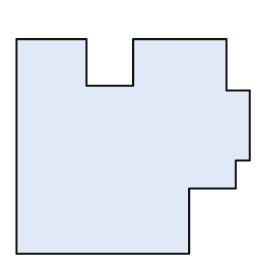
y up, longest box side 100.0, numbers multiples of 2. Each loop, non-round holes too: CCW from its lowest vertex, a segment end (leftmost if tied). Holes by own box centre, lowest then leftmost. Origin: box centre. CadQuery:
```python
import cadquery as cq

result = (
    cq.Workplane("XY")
    .moveTo(-50.0, -46.0)
    .lineTo(24.0, -46.0)
    .lineTo(24.0, -18.0)
    .lineTo(44.0, -18.0)
    .lineTo(44.0, -6.0)
    .lineTo(50.0, -6.0)
    .lineTo(50.0, 24.0)
    .lineTo(40.0, 24.0)
    .lineTo(40.0, 46.0)
    .lineTo(0.0, 46.0)
    .lineTo(0.0, 26.0)
    .lineTo(-20.0, 26.0)
    .lineTo(-20.0, 46.0)
    .lineTo(-50.0, 46.0)
    .close()
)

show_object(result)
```